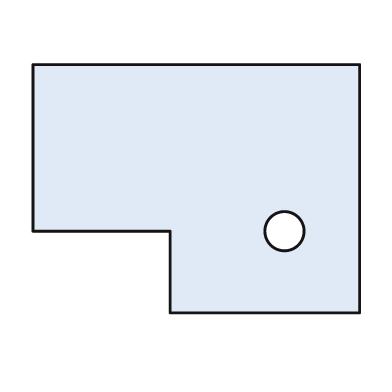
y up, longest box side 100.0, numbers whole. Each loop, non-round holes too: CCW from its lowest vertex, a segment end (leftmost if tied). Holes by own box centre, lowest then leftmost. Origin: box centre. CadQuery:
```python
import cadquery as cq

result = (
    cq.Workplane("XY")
    .moveTo(-8.0, -38.0)
    .lineTo(50.0, -38.0)
    .lineTo(50.0, 38.0)
    .lineTo(-50.0, 38.0)
    .lineTo(-50.0, -13.0)
    .lineTo(-8.0, -13.0)
    .close()
    .moveTo(27.0, -13.0)
    .circle(6.0)
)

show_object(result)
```